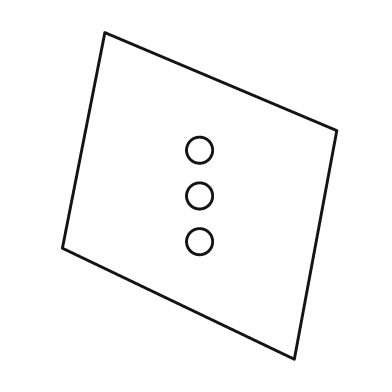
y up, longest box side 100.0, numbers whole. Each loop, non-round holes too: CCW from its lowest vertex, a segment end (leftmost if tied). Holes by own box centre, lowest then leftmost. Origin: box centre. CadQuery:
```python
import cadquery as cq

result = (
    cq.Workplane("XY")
    .moveTo(29.0, -50.0)
    .lineTo(42.0, 20.0)
    .lineTo(-29.0, 50.0)
    .lineTo(-42.0, -16.0)
    .close()
    .moveTo(0.0, -14.0)
    .circle(4.0)
    .moveTo(0.0, 0.0)
    .circle(4.0)
    .moveTo(0.0, 14.0)
    .circle(4.0)
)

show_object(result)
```